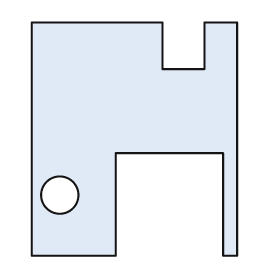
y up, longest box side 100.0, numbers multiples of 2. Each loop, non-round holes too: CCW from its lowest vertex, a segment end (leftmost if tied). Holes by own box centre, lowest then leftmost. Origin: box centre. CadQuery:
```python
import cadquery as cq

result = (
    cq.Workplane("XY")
    .moveTo(-44.0, -50.0)
    .lineTo(-8.0, -50.0)
    .lineTo(-8.0, -6.0)
    .lineTo(38.0, -6.0)
    .lineTo(38.0, -50.0)
    .lineTo(44.0, -50.0)
    .lineTo(44.0, 50.0)
    .lineTo(30.0, 50.0)
    .lineTo(30.0, 30.0)
    .lineTo(12.0, 30.0)
    .lineTo(12.0, 50.0)
    .lineTo(-44.0, 50.0)
    .close()
    .moveTo(-32.0, -24.0)
    .circle(8.0)
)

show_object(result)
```